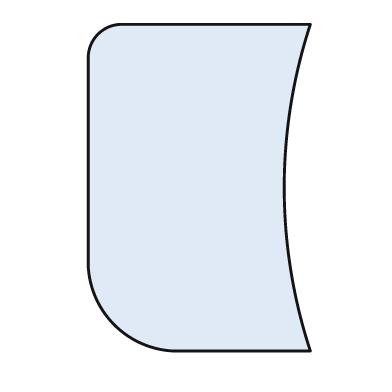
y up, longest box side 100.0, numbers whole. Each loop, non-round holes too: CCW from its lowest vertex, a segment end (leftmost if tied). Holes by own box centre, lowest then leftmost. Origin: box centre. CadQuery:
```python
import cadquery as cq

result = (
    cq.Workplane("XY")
    .moveTo(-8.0, -50.0)
    .lineTo(34.0, -50.0)
    .threePointArc((26.0, 0.0), (34.0, 50.0))
    .lineTo(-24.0, 50.0)
    .threePointArc((-31.0, 47.0), (-34.0, 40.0))
    .lineTo(-34.0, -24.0)
    .threePointArc((-26.0, -42.0), (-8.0, -50.0))
    .close()
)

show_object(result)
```